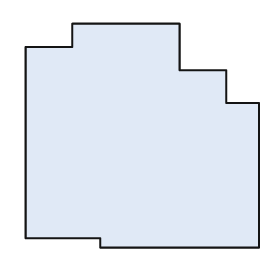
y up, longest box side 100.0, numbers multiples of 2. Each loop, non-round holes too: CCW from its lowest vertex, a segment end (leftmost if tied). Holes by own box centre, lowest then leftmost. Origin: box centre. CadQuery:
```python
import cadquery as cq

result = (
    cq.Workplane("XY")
    .moveTo(-18.0, -48.0)
    .lineTo(50.0, -48.0)
    .lineTo(50.0, 14.0)
    .lineTo(36.0, 14.0)
    .lineTo(36.0, 28.0)
    .lineTo(16.0, 28.0)
    .lineTo(16.0, 48.0)
    .lineTo(-30.0, 48.0)
    .lineTo(-30.0, 38.0)
    .lineTo(-50.0, 38.0)
    .lineTo(-50.0, -44.0)
    .lineTo(-18.0, -44.0)
    .close()
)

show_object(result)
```